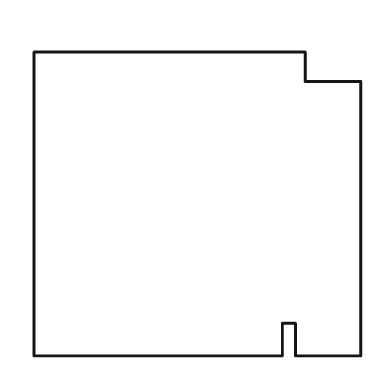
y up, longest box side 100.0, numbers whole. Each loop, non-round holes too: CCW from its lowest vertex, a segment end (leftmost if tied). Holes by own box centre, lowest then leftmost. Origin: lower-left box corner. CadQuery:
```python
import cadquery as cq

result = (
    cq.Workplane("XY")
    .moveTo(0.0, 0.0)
    .lineTo(76.0, 0.0)
    .lineTo(76.0, 10.0)
    .lineTo(80.0, 10.0)
    .lineTo(80.0, 0.0)
    .lineTo(100.0, 0.0)
    .lineTo(100.0, 84.0)
    .lineTo(83.0, 84.0)
    .lineTo(83.0, 93.0)
    .lineTo(0.0, 93.0)
    .close()
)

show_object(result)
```